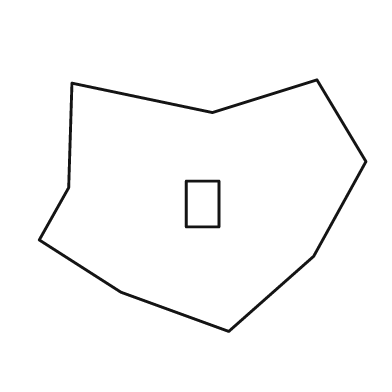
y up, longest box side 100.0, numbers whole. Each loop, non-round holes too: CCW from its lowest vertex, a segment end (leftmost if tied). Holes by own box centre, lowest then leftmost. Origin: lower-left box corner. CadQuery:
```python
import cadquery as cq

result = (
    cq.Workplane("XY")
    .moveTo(58.0, 0.0)
    .lineTo(84.0, 23.0)
    .lineTo(100.0, 52.0)
    .lineTo(85.0, 77.0)
    .lineTo(53.0, 67.0)
    .lineTo(10.0, 76.0)
    .lineTo(9.0, 44.0)
    .lineTo(0.0, 28.0)
    .lineTo(25.0, 12.0)
    .close()
    .moveTo(45.0, 32.0)
    .lineTo(55.0, 32.0)
    .lineTo(55.0, 46.0)
    .lineTo(45.0, 46.0)
    .close()
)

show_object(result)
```